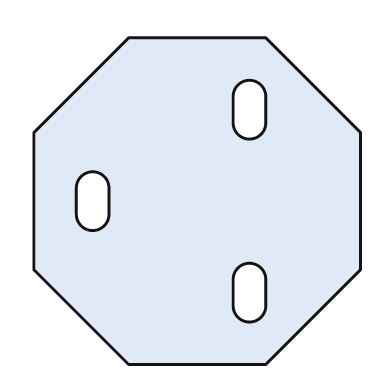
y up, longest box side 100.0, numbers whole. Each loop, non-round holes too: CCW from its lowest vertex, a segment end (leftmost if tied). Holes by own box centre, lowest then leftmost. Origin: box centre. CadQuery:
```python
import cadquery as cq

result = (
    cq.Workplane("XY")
    .moveTo(-21.0, -50.0)
    .lineTo(21.0, -50.0)
    .lineTo(50.0, -21.0)
    .lineTo(50.0, 21.0)
    .lineTo(21.0, 50.0)
    .lineTo(-21.0, 50.0)
    .lineTo(-50.0, 21.0)
    .lineTo(-50.0, -21.0)
    .close()
    .moveTo(11.0, -32.0)
    .threePointArc((16.0, -37.0), (21.0, -32.0))
    .lineTo(21.0, -24.0)
    .threePointArc((16.0, -19.0), (11.0, -24.0))
    .close()
    .moveTo(-37.0, -4.0)
    .threePointArc((-32.0, -9.0), (-27.0, -4.0))
    .lineTo(-27.0, 4.0)
    .threePointArc((-32.0, 9.0), (-37.0, 4.0))
    .close()
    .moveTo(11.0, 24.0)
    .threePointArc((16.0, 19.0), (21.0, 24.0))
    .lineTo(21.0, 32.0)
    .threePointArc((16.0, 37.0), (11.0, 32.0))
    .close()
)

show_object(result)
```